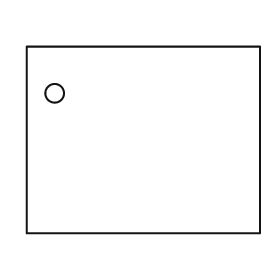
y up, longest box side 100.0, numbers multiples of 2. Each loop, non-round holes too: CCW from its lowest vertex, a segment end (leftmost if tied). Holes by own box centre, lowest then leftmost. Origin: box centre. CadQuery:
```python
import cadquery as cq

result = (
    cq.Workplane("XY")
    .moveTo(-50.0, -40.0)
    .lineTo(50.0, -40.0)
    .lineTo(50.0, 40.0)
    .lineTo(-50.0, 40.0)
    .close()
    .moveTo(-38.0, 20.0)
    .circle(4.0)
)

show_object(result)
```